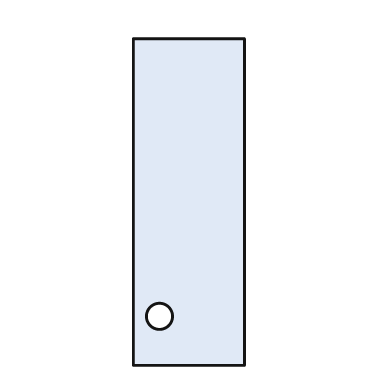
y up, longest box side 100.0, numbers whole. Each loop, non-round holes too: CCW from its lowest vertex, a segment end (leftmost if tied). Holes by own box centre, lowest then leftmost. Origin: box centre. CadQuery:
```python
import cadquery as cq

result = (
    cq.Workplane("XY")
    .moveTo(-17.0, -50.0)
    .lineTo(17.0, -50.0)
    .lineTo(17.0, 50.0)
    .lineTo(-17.0, 50.0)
    .close()
    .moveTo(-9.0, -35.0)
    .circle(4.0)
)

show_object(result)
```